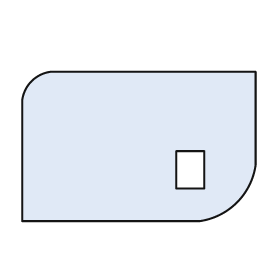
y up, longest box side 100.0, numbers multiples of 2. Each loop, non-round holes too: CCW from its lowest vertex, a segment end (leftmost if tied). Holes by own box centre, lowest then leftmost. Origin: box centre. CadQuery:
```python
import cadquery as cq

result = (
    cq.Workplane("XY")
    .moveTo(-50.0, -32.0)
    .lineTo(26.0, -32.0)
    .threePointArc((42.0, -24.0), (50.0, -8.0))
    .lineTo(50.0, 32.0)
    .lineTo(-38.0, 32.0)
    .threePointArc((-46.0, 28.0), (-50.0, 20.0))
    .close()
    .moveTo(16.0, -18.0)
    .lineTo(28.0, -18.0)
    .lineTo(28.0, -2.0)
    .lineTo(16.0, -2.0)
    .close()
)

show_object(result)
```